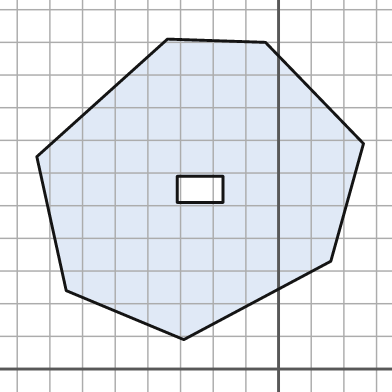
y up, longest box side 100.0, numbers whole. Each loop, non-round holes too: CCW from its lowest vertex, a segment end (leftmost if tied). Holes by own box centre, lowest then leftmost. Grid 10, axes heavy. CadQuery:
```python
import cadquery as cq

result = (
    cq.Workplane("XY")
    .moveTo(-29.0, 9.0)
    .lineTo(16.0, 33.0)
    .lineTo(26.0, 69.0)
    .lineTo(-4.0, 100.0)
    .lineTo(-34.0, 101.0)
    .lineTo(-74.0, 65.0)
    .lineTo(-65.0, 24.0)
    .close()
    .moveTo(-31.0, 51.0)
    .lineTo(-17.0, 51.0)
    .lineTo(-17.0, 59.0)
    .lineTo(-31.0, 59.0)
    .close()
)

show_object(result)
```